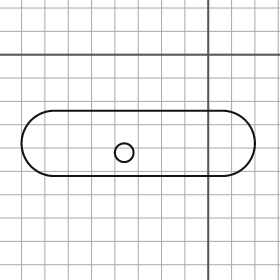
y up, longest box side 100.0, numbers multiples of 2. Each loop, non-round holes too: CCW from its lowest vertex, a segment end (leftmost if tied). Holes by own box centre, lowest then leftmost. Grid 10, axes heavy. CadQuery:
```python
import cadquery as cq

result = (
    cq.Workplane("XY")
    .moveTo(-66.0, -52.0)
    .lineTo(6.0, -52.0)
    .threePointArc((20.0, -38.0), (6.0, -24.0))
    .lineTo(-66.0, -24.0)
    .threePointArc((-80.0, -38.0), (-66.0, -52.0))
    .close()
    .moveTo(-36.0, -42.0)
    .circle(4.0)
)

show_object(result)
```